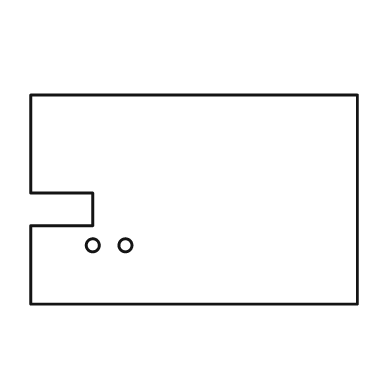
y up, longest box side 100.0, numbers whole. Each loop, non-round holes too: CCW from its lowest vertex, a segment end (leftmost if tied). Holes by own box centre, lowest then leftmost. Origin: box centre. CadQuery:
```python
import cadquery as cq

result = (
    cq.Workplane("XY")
    .moveTo(-50.0, -32.0)
    .lineTo(50.0, -32.0)
    .lineTo(50.0, 32.0)
    .lineTo(-50.0, 32.0)
    .lineTo(-50.0, 2.0)
    .lineTo(-31.0, 2.0)
    .lineTo(-31.0, -8.0)
    .lineTo(-50.0, -8.0)
    .close()
    .moveTo(-31.0, -14.0)
    .circle(2.0)
    .moveTo(-21.0, -14.0)
    .circle(2.0)
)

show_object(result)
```